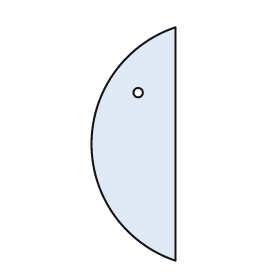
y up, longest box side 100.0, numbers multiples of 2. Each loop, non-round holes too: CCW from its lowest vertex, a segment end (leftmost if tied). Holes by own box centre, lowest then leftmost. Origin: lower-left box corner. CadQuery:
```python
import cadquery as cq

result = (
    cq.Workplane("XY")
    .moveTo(36.0, 0.0)
    .lineTo(36.0, 100.0)
    .threePointArc((0.0, 50.0), (36.0, 0.0))
    .close()
    .moveTo(20.0, 72.0)
    .circle(2.0)
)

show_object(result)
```